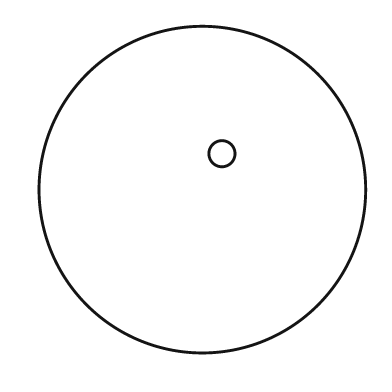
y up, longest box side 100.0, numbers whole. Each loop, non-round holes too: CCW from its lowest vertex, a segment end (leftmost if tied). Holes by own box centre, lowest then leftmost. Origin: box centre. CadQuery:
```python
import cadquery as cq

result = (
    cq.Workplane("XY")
    .moveTo(0.0, 0.0)
    .circle(50.0)
    .moveTo(6.0, 11.0)
    .circle(4.0)
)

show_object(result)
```